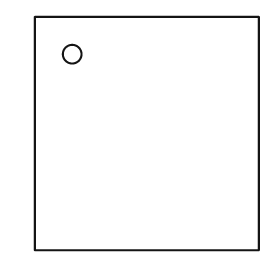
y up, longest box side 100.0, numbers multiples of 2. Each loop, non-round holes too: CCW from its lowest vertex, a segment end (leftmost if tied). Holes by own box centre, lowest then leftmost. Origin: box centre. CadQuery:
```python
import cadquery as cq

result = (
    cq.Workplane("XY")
    .moveTo(-48.0, -50.0)
    .lineTo(48.0, -50.0)
    .lineTo(48.0, 50.0)
    .lineTo(-48.0, 50.0)
    .close()
    .moveTo(-32.0, 34.0)
    .circle(4.0)
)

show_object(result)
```